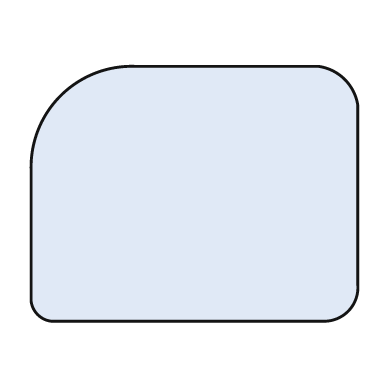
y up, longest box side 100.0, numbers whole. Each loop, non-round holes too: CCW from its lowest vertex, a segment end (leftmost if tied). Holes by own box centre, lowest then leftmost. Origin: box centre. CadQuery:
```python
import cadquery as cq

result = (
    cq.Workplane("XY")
    .moveTo(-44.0, -39.0)
    .lineTo(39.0, -39.0)
    .threePointArc((47.0, -36.0), (50.0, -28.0))
    .lineTo(50.0, 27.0)
    .threePointArc((46.0, 35.0), (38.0, 39.0))
    .lineTo(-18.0, 39.0)
    .threePointArc((-41.0, 30.0), (-50.0, 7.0))
    .lineTo(-50.0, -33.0)
    .threePointArc((-48.0, -37.0), (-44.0, -39.0))
    .close()
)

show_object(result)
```